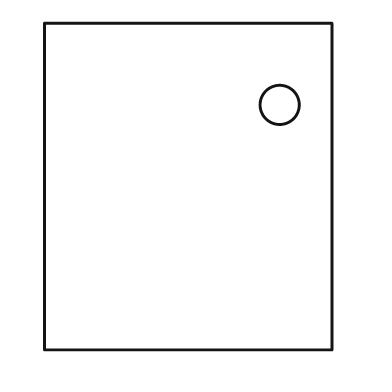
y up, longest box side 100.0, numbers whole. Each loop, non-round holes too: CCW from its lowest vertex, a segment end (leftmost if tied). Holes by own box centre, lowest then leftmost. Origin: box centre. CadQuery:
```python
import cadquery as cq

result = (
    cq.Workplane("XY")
    .moveTo(-44.0, -50.0)
    .lineTo(44.0, -50.0)
    .lineTo(44.0, 50.0)
    .lineTo(-44.0, 50.0)
    .close()
    .moveTo(28.0, 25.0)
    .circle(6.0)
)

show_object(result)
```